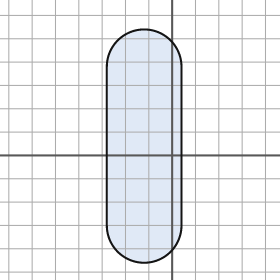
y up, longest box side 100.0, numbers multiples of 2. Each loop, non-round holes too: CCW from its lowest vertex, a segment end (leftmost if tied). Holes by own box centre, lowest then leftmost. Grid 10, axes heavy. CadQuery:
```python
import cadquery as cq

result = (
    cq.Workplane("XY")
    .moveTo(-28.0, -30.0)
    .threePointArc((-12.0, -46.0), (4.0, -30.0))
    .lineTo(4.0, 38.0)
    .threePointArc((-12.0, 54.0), (-28.0, 38.0))
    .close()
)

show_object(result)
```